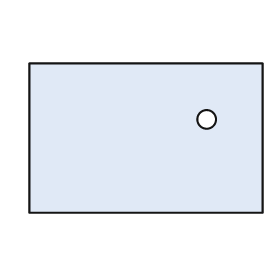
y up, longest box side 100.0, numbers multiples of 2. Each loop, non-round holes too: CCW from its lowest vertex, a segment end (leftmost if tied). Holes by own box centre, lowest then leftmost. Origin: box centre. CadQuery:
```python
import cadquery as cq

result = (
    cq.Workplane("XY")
    .moveTo(-50.0, -32.0)
    .lineTo(50.0, -32.0)
    .lineTo(50.0, 32.0)
    .lineTo(-50.0, 32.0)
    .close()
    .moveTo(26.0, 8.0)
    .circle(4.0)
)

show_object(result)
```